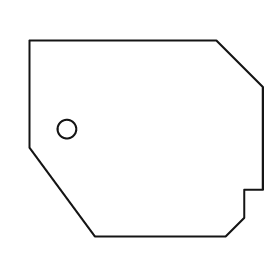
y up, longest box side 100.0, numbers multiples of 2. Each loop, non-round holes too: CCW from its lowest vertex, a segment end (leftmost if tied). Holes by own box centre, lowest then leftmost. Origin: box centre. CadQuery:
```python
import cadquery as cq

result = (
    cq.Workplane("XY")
    .moveTo(-22.0, -42.0)
    .lineTo(34.0, -42.0)
    .lineTo(42.0, -34.0)
    .lineTo(42.0, -22.0)
    .lineTo(50.0, -22.0)
    .lineTo(50.0, 22.0)
    .lineTo(30.0, 42.0)
    .lineTo(-50.0, 42.0)
    .lineTo(-50.0, -4.0)
    .close()
    .moveTo(-34.0, 4.0)
    .circle(4.0)
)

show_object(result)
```